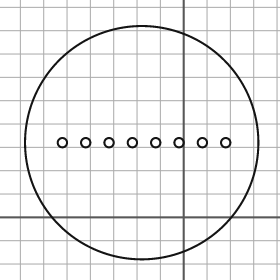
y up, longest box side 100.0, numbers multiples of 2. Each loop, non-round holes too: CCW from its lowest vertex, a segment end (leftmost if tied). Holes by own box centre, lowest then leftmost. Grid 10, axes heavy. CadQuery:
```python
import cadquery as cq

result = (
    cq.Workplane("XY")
    .moveTo(-18.0, 32.0)
    .circle(50.0)
    .moveTo(-52.0, 32.0)
    .circle(2.0)
    .moveTo(-42.0, 32.0)
    .circle(2.0)
    .moveTo(-32.0, 32.0)
    .circle(2.0)
    .moveTo(-22.0, 32.0)
    .circle(2.0)
    .moveTo(-12.0, 32.0)
    .circle(2.0)
    .moveTo(-2.0, 32.0)
    .circle(2.0)
    .moveTo(8.0, 32.0)
    .circle(2.0)
    .moveTo(18.0, 32.0)
    .circle(2.0)
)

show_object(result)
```